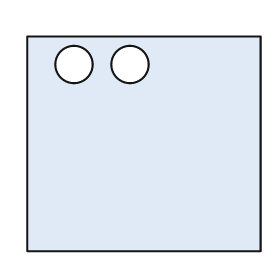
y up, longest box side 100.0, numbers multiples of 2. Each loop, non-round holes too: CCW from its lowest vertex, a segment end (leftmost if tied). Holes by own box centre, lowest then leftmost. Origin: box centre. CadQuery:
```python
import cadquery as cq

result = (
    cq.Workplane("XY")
    .moveTo(-50.0, -46.0)
    .lineTo(50.0, -46.0)
    .lineTo(50.0, 46.0)
    .lineTo(-50.0, 46.0)
    .close()
    .moveTo(-30.0, 34.0)
    .circle(8.0)
    .moveTo(-6.0, 34.0)
    .circle(8.0)
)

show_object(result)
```